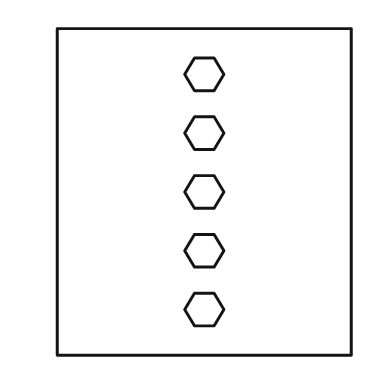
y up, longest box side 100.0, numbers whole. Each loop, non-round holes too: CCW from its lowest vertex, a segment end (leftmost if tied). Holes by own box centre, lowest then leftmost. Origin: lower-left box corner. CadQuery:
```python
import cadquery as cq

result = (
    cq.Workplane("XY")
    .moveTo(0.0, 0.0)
    .lineTo(90.0, 0.0)
    .lineTo(90.0, 100.0)
    .lineTo(0.0, 100.0)
    .close()
    .moveTo(42.0, 9.0)
    .lineTo(48.0, 9.0)
    .lineTo(51.0, 14.0)
    .lineTo(48.0, 19.0)
    .lineTo(42.0, 19.0)
    .lineTo(39.0, 14.0)
    .close()
    .moveTo(42.0, 27.0)
    .lineTo(48.0, 27.0)
    .lineTo(51.0, 32.0)
    .lineTo(48.0, 37.0)
    .lineTo(42.0, 37.0)
    .lineTo(39.0, 32.0)
    .close()
    .moveTo(42.0, 45.0)
    .lineTo(48.0, 45.0)
    .lineTo(51.0, 50.0)
    .lineTo(48.0, 55.0)
    .lineTo(42.0, 55.0)
    .lineTo(39.0, 50.0)
    .close()
    .moveTo(42.0, 63.0)
    .lineTo(48.0, 63.0)
    .lineTo(51.0, 68.0)
    .lineTo(48.0, 73.0)
    .lineTo(42.0, 73.0)
    .lineTo(39.0, 68.0)
    .close()
    .moveTo(42.0, 81.0)
    .lineTo(48.0, 81.0)
    .lineTo(51.0, 86.0)
    .lineTo(48.0, 91.0)
    .lineTo(42.0, 91.0)
    .lineTo(39.0, 86.0)
    .close()
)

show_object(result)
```